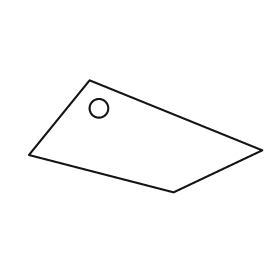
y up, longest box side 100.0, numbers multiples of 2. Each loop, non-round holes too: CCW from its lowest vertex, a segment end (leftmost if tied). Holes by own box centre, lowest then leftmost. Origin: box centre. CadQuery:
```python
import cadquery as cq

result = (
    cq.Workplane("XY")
    .moveTo(12.0, -24.0)
    .lineTo(50.0, -6.0)
    .lineTo(-24.0, 24.0)
    .lineTo(-50.0, -8.0)
    .close()
    .moveTo(-20.0, 12.0)
    .circle(4.0)
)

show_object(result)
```